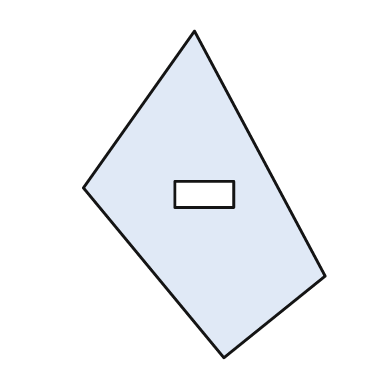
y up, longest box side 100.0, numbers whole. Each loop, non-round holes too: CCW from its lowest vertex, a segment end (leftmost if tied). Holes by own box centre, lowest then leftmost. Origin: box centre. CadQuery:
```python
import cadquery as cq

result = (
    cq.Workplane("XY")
    .moveTo(6.0, -50.0)
    .lineTo(37.0, -25.0)
    .lineTo(-3.0, 50.0)
    .lineTo(-37.0, 2.0)
    .close()
    .moveTo(-9.0, -4.0)
    .lineTo(9.0, -4.0)
    .lineTo(9.0, 4.0)
    .lineTo(-9.0, 4.0)
    .close()
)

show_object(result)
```